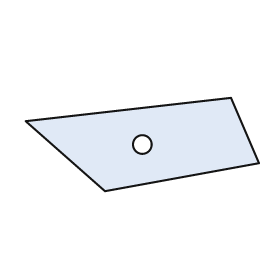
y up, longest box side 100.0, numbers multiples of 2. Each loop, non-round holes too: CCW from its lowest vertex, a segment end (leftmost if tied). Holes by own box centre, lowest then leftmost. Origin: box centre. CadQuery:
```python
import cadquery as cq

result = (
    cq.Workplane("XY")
    .moveTo(-16.0, -20.0)
    .lineTo(50.0, -8.0)
    .lineTo(38.0, 20.0)
    .lineTo(-50.0, 10.0)
    .close()
    .moveTo(0.0, 0.0)
    .circle(4.0)
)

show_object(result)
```